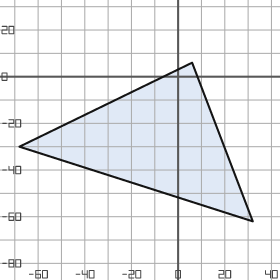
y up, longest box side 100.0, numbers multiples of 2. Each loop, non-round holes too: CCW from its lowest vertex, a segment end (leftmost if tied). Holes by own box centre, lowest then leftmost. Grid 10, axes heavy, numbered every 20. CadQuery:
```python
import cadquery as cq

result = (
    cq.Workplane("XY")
    .moveTo(32.0, -62.0)
    .lineTo(6.0, 6.0)
    .lineTo(-68.0, -30.0)
    .close()
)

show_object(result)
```